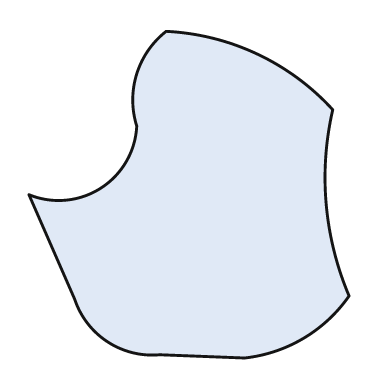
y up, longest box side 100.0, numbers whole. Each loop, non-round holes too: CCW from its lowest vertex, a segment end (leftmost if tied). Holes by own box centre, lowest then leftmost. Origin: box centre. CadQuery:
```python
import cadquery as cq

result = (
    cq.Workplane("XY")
    .moveTo(17.0, -50.0)
    .threePointArc((35.0, -44.0), (49.0, -31.0))
    .threePointArc((42.0, -3.0), (44.0, 26.0))
    .threePointArc((21.0, 43.0), (-7.0, 50.0))
    .threePointArc((-16.0, 37.0), (-16.0, 21.0))
    .threePointArc((-27.0, 2.0), (-49.0, 0.0))
    .lineTo(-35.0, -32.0)
    .threePointArc((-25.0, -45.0), (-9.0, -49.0))
    .close()
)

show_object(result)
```